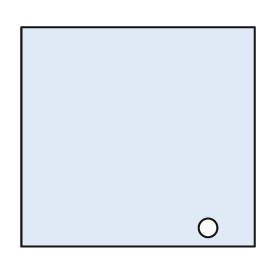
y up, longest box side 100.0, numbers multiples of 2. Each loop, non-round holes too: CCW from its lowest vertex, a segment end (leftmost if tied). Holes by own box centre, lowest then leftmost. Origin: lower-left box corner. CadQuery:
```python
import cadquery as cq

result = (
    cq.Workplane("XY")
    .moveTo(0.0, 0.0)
    .lineTo(100.0, 0.0)
    .lineTo(100.0, 94.0)
    .lineTo(0.0, 94.0)
    .close()
    .moveTo(80.0, 8.0)
    .circle(4.0)
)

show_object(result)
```